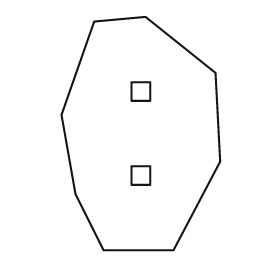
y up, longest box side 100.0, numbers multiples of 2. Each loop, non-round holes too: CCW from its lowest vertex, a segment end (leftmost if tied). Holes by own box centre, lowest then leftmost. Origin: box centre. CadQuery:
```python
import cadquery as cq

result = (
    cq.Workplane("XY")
    .moveTo(-16.0, -50.0)
    .lineTo(14.0, -50.0)
    .lineTo(34.0, -12.0)
    .lineTo(32.0, 26.0)
    .lineTo(2.0, 50.0)
    .lineTo(-20.0, 48.0)
    .lineTo(-34.0, 8.0)
    .lineTo(-28.0, -26.0)
    .close()
    .moveTo(-4.0, -22.0)
    .lineTo(4.0, -22.0)
    .lineTo(4.0, -14.0)
    .lineTo(-4.0, -14.0)
    .close()
    .moveTo(-4.0, 14.0)
    .lineTo(4.0, 14.0)
    .lineTo(4.0, 22.0)
    .lineTo(-4.0, 22.0)
    .close()
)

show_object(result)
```